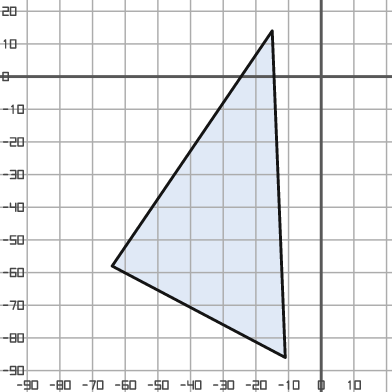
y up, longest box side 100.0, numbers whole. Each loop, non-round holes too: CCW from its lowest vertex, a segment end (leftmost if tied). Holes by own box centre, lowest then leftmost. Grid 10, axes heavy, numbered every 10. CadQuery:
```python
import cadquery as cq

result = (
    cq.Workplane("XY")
    .moveTo(-11.0, -86.0)
    .lineTo(-15.0, 14.0)
    .lineTo(-64.0, -58.0)
    .close()
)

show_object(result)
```